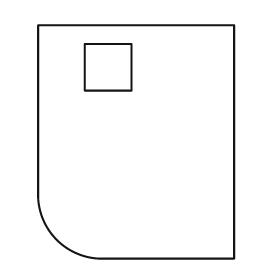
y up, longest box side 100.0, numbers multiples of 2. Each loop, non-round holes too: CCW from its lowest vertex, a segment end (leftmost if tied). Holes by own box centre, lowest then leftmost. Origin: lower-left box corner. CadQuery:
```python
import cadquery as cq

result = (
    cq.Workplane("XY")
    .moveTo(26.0, 0.0)
    .lineTo(84.0, 0.0)
    .lineTo(84.0, 100.0)
    .lineTo(0.0, 100.0)
    .lineTo(0.0, 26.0)
    .threePointArc((8.0, 8.0), (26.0, 0.0))
    .close()
    .moveTo(20.0, 72.0)
    .lineTo(40.0, 72.0)
    .lineTo(40.0, 92.0)
    .lineTo(20.0, 92.0)
    .close()
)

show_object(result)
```